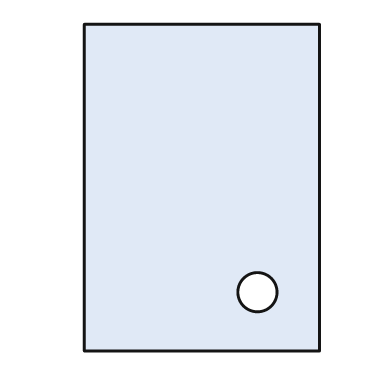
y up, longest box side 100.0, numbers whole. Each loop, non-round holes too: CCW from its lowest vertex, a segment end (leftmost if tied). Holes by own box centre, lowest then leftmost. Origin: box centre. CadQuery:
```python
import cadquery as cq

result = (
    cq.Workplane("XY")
    .moveTo(-36.0, -50.0)
    .lineTo(36.0, -50.0)
    .lineTo(36.0, 50.0)
    .lineTo(-36.0, 50.0)
    .close()
    .moveTo(17.0, -32.0)
    .circle(6.0)
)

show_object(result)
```